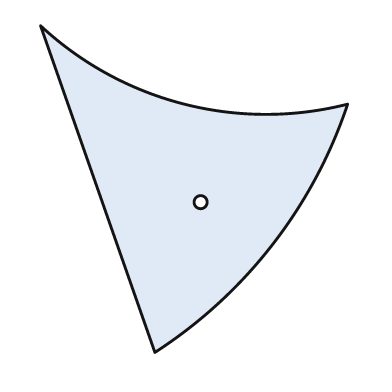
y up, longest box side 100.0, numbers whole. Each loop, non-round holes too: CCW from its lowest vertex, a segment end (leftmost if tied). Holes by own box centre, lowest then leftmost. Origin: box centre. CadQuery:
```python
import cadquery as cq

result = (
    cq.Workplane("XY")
    .moveTo(-12.0, -50.0)
    .threePointArc((24.0, -17.0), (47.0, 26.0))
    .threePointArc((-3.0, 26.0), (-47.0, 50.0))
    .close()
    .moveTo(2.0, -4.0)
    .circle(2.0)
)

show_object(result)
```